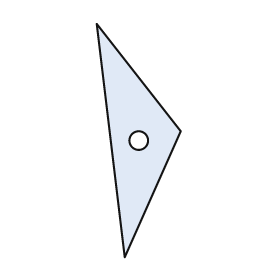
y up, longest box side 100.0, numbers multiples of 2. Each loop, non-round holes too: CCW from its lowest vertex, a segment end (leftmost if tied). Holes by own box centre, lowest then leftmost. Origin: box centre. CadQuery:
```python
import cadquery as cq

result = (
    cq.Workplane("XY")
    .moveTo(-6.0, -50.0)
    .lineTo(18.0, 4.0)
    .lineTo(-18.0, 50.0)
    .close()
    .moveTo(0.0, 0.0)
    .circle(4.0)
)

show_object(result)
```